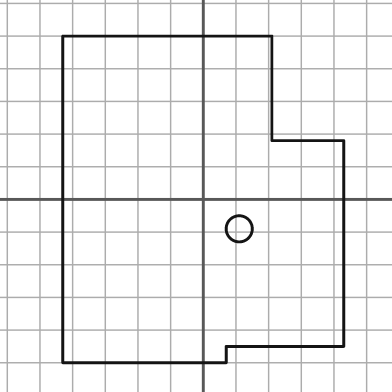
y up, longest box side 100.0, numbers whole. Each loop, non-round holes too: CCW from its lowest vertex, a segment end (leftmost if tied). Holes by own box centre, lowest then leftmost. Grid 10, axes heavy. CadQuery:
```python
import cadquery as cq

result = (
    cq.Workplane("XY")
    .moveTo(-43.0, -50.0)
    .lineTo(7.0, -50.0)
    .lineTo(7.0, -45.0)
    .lineTo(43.0, -45.0)
    .lineTo(43.0, 18.0)
    .lineTo(21.0, 18.0)
    .lineTo(21.0, 50.0)
    .lineTo(-43.0, 50.0)
    .close()
    .moveTo(11.0, -9.0)
    .circle(4.0)
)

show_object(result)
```